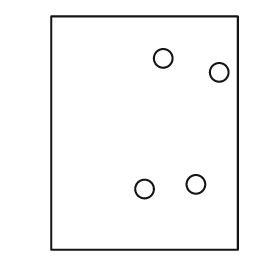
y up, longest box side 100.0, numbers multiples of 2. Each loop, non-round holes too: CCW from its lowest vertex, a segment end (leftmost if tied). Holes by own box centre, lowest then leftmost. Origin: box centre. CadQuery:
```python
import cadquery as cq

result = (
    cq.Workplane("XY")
    .moveTo(-40.0, -50.0)
    .lineTo(40.0, -50.0)
    .lineTo(40.0, 50.0)
    .lineTo(-40.0, 50.0)
    .close()
    .moveTo(0.0, -24.0)
    .circle(4.0)
    .moveTo(22.0, -22.0)
    .circle(4.0)
    .moveTo(32.0, 26.0)
    .circle(4.0)
    .moveTo(8.0, 32.0)
    .circle(4.0)
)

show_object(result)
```